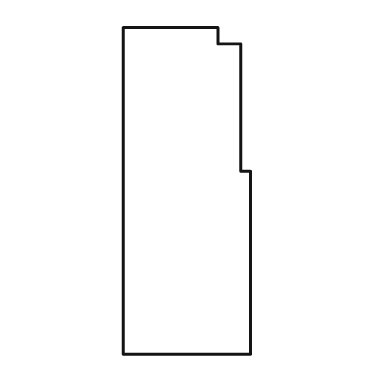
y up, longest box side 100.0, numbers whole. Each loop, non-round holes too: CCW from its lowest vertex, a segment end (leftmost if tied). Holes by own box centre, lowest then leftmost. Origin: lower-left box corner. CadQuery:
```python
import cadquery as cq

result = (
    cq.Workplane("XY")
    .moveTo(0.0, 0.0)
    .lineTo(39.0, 0.0)
    .lineTo(39.0, 56.0)
    .lineTo(36.0, 56.0)
    .lineTo(36.0, 95.0)
    .lineTo(29.0, 95.0)
    .lineTo(29.0, 100.0)
    .lineTo(0.0, 100.0)
    .close()
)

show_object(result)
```